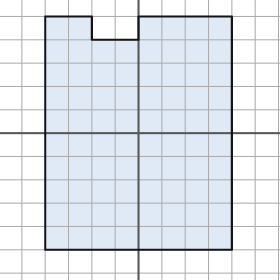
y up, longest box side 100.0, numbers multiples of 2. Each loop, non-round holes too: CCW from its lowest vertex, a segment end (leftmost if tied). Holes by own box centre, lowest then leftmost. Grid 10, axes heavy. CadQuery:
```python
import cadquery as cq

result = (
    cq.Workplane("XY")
    .moveTo(-40.0, -50.0)
    .lineTo(40.0, -50.0)
    .lineTo(40.0, 50.0)
    .lineTo(0.0, 50.0)
    .lineTo(0.0, 40.0)
    .lineTo(-20.0, 40.0)
    .lineTo(-20.0, 50.0)
    .lineTo(-40.0, 50.0)
    .close()
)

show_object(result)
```